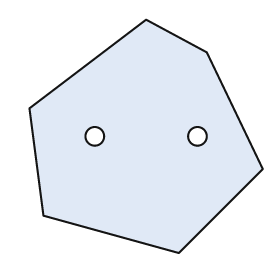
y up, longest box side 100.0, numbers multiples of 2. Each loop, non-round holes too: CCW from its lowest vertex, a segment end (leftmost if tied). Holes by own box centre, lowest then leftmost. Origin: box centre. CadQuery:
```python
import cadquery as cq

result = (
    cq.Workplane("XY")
    .moveTo(14.0, -50.0)
    .lineTo(50.0, -14.0)
    .lineTo(26.0, 36.0)
    .lineTo(0.0, 50.0)
    .lineTo(-50.0, 12.0)
    .lineTo(-44.0, -34.0)
    .close()
    .moveTo(-22.0, 0.0)
    .circle(4.0)
    .moveTo(22.0, 0.0)
    .circle(4.0)
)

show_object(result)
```